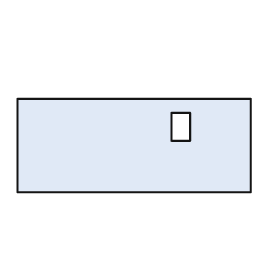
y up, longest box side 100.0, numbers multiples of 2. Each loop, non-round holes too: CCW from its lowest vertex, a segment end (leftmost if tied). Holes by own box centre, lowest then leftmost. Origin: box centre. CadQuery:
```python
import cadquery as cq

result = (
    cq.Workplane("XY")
    .moveTo(-50.0, -20.0)
    .lineTo(50.0, -20.0)
    .lineTo(50.0, 20.0)
    .lineTo(-50.0, 20.0)
    .close()
    .moveTo(16.0, 2.0)
    .lineTo(24.0, 2.0)
    .lineTo(24.0, 14.0)
    .lineTo(16.0, 14.0)
    .close()
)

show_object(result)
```